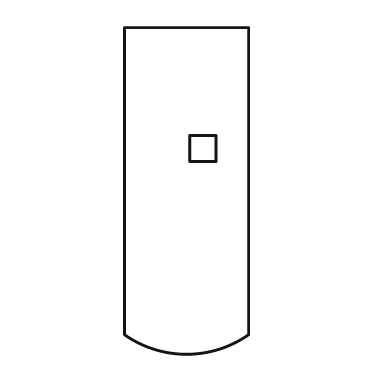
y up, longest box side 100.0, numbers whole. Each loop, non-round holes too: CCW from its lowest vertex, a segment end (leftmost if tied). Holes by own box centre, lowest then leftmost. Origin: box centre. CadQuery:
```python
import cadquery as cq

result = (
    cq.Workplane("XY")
    .moveTo(-19.0, -44.0)
    .threePointArc((0.0, -50.0), (19.0, -44.0))
    .lineTo(19.0, 50.0)
    .lineTo(-19.0, 50.0)
    .close()
    .moveTo(1.0, 9.0)
    .lineTo(9.0, 9.0)
    .lineTo(9.0, 17.0)
    .lineTo(1.0, 17.0)
    .close()
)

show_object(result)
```